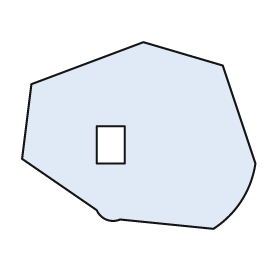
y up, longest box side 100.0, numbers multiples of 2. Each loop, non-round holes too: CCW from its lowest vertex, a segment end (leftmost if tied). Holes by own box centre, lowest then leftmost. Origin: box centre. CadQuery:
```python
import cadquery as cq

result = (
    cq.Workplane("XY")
    .moveTo(32.0, -40.0)
    .threePointArc((44.0, -28.0), (50.0, -12.0))
    .lineTo(36.0, 30.0)
    .lineTo(2.0, 40.0)
    .lineTo(-46.0, 22.0)
    .lineTo(-50.0, -10.0)
    .lineTo(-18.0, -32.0)
    .threePointArc((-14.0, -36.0), (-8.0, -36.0))
    .close()
    .moveTo(-18.0, -12.0)
    .lineTo(-6.0, -12.0)
    .lineTo(-6.0, 4.0)
    .lineTo(-18.0, 4.0)
    .close()
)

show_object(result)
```